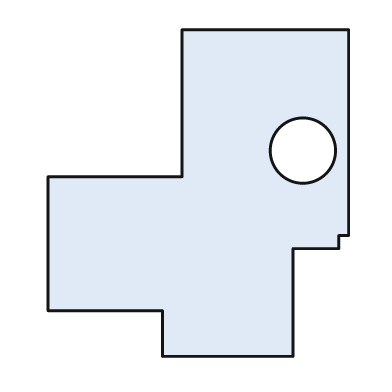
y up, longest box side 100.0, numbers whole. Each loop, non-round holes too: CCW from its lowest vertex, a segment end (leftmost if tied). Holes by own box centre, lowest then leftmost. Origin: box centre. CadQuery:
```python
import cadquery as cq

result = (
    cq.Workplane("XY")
    .moveTo(-11.0, -50.0)
    .lineTo(29.0, -50.0)
    .lineTo(29.0, -17.0)
    .lineTo(43.0, -17.0)
    .lineTo(43.0, -13.0)
    .lineTo(46.0, -13.0)
    .lineTo(46.0, 50.0)
    .lineTo(-5.0, 50.0)
    .lineTo(-5.0, 5.0)
    .lineTo(-46.0, 5.0)
    .lineTo(-46.0, -36.0)
    .lineTo(-11.0, -36.0)
    .close()
    .moveTo(32.0, 13.0)
    .circle(10.0)
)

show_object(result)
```